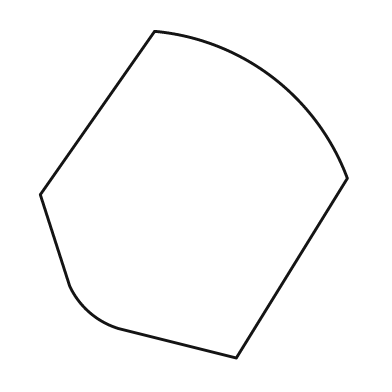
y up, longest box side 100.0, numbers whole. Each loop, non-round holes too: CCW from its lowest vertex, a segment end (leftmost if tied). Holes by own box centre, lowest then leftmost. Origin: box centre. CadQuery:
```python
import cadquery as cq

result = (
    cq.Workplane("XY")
    .moveTo(13.0, -50.0)
    .lineTo(47.0, 5.0)
    .threePointArc((24.0, 36.0), (-12.0, 50.0))
    .lineTo(-47.0, 0.0)
    .lineTo(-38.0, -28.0)
    .threePointArc((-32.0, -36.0), (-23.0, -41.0))
    .close()
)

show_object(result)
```